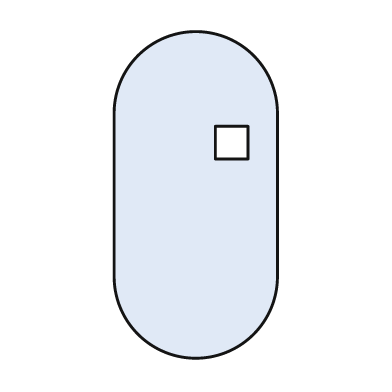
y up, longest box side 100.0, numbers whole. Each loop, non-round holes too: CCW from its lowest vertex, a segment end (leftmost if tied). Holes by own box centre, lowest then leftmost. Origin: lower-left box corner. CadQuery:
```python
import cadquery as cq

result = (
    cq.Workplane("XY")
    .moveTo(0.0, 25.0)
    .threePointArc((25.0, 0.0), (50.0, 25.0))
    .lineTo(50.0, 75.0)
    .threePointArc((25.0, 100.0), (0.0, 75.0))
    .close()
    .moveTo(31.0, 61.0)
    .lineTo(41.0, 61.0)
    .lineTo(41.0, 71.0)
    .lineTo(31.0, 71.0)
    .close()
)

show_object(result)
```